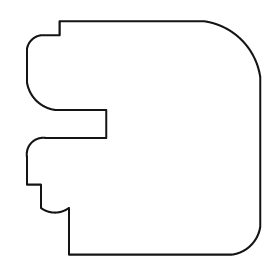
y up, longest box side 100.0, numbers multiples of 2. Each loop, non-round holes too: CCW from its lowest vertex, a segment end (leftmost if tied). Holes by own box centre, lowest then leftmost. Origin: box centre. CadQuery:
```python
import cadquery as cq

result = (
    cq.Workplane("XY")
    .moveTo(-32.0, -50.0)
    .lineTo(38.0, -50.0)
    .threePointArc((46.0, -46.0), (50.0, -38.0))
    .lineTo(50.0, 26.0)
    .threePointArc((42.0, 42.0), (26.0, 50.0))
    .lineTo(-36.0, 50.0)
    .lineTo(-36.0, 44.0)
    .lineTo(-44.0, 44.0)
    .threePointArc((-48.0, 42.0), (-50.0, 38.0))
    .lineTo(-50.0, 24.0)
    .threePointArc((-46.0, 16.0), (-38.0, 12.0))
    .lineTo(-16.0, 12.0)
    .lineTo(-16.0, 0.0)
    .lineTo(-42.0, 0.0)
    .threePointArc((-48.0, -2.0), (-50.0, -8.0))
    .lineTo(-50.0, -20.0)
    .lineTo(-44.0, -20.0)
    .lineTo(-44.0, -30.0)
    .threePointArc((-38.0, -32.0), (-32.0, -30.0))
    .close()
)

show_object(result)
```